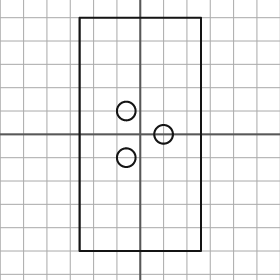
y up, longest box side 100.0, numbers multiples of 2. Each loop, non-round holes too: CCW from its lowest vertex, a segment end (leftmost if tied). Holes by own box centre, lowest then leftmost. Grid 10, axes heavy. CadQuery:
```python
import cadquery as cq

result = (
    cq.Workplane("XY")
    .moveTo(-26.0, -50.0)
    .lineTo(26.0, -50.0)
    .lineTo(26.0, 50.0)
    .lineTo(-26.0, 50.0)
    .close()
    .moveTo(-6.0, -10.0)
    .circle(4.0)
    .moveTo(10.0, 0.0)
    .circle(4.0)
    .moveTo(-6.0, 10.0)
    .circle(4.0)
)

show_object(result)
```